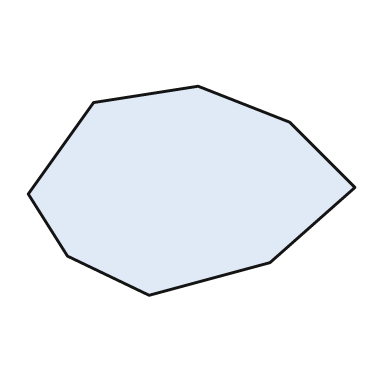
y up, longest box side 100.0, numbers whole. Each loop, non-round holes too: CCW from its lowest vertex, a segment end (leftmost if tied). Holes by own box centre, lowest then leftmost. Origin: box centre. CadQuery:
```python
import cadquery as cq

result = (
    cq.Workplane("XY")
    .moveTo(-13.0, -32.0)
    .lineTo(24.0, -22.0)
    .lineTo(50.0, 1.0)
    .lineTo(30.0, 21.0)
    .lineTo(2.0, 32.0)
    .lineTo(-30.0, 27.0)
    .lineTo(-50.0, -1.0)
    .lineTo(-38.0, -20.0)
    .close()
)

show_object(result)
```